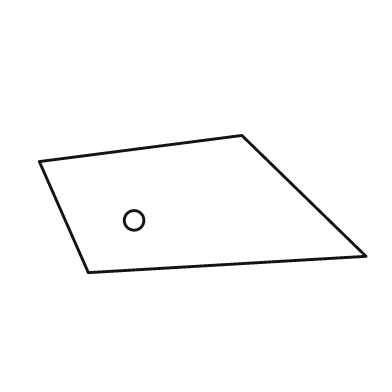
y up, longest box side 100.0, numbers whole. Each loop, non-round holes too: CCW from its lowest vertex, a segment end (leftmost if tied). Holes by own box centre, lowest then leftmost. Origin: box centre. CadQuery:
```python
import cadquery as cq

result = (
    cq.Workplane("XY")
    .moveTo(-35.0, -21.0)
    .lineTo(50.0, -16.0)
    .lineTo(12.0, 21.0)
    .lineTo(-50.0, 13.0)
    .close()
    .moveTo(-21.0, -5.0)
    .circle(3.0)
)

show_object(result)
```